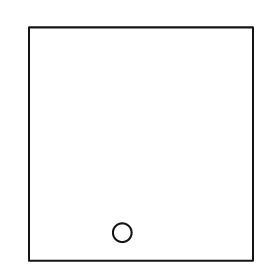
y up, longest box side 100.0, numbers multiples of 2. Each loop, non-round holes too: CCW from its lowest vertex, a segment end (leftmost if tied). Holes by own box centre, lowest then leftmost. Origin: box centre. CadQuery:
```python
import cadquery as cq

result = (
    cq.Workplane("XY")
    .moveTo(-48.0, -50.0)
    .lineTo(48.0, -50.0)
    .lineTo(48.0, 50.0)
    .lineTo(-48.0, 50.0)
    .close()
    .moveTo(-8.0, -38.0)
    .circle(4.0)
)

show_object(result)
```